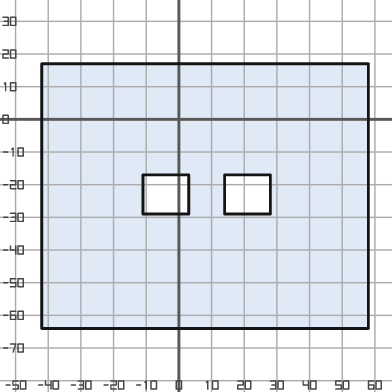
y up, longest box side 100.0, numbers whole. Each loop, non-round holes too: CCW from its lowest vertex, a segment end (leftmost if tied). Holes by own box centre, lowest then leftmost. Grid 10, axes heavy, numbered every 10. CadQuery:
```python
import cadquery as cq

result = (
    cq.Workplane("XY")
    .moveTo(-42.0, -64.0)
    .lineTo(58.0, -64.0)
    .lineTo(58.0, 17.0)
    .lineTo(-42.0, 17.0)
    .close()
    .moveTo(-11.0, -29.0)
    .lineTo(3.0, -29.0)
    .lineTo(3.0, -17.0)
    .lineTo(-11.0, -17.0)
    .close()
    .moveTo(14.0, -29.0)
    .lineTo(28.0, -29.0)
    .lineTo(28.0, -17.0)
    .lineTo(14.0, -17.0)
    .close()
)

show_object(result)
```